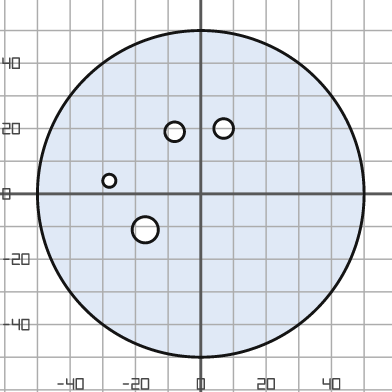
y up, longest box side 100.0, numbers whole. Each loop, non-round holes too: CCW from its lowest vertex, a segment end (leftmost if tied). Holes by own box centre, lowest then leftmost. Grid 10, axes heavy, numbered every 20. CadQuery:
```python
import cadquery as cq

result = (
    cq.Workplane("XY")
    .moveTo(0.0, 0.0)
    .circle(50.0)
    .moveTo(-17.0, -11.0)
    .circle(4.0)
    .moveTo(-28.0, 4.0)
    .circle(2.0)
    .moveTo(-8.0, 19.0)
    .circle(3.0)
    .moveTo(7.0, 20.0)
    .circle(3.0)
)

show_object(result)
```